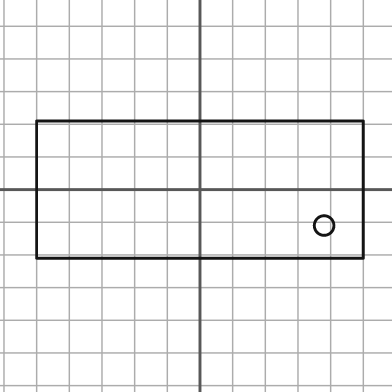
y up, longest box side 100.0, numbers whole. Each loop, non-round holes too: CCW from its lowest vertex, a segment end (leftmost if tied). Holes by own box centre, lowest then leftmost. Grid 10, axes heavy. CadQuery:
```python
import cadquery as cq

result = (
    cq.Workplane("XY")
    .moveTo(-50.0, -21.0)
    .lineTo(50.0, -21.0)
    .lineTo(50.0, 21.0)
    .lineTo(-50.0, 21.0)
    .close()
    .moveTo(38.0, -11.0)
    .circle(3.0)
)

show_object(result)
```